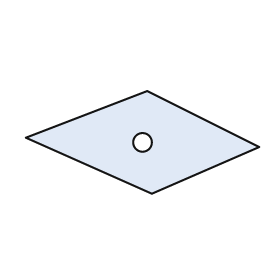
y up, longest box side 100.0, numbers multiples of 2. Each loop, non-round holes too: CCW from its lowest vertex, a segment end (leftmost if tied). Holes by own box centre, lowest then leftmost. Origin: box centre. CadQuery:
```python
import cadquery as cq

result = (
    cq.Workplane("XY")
    .moveTo(4.0, -22.0)
    .lineTo(50.0, -2.0)
    .lineTo(2.0, 22.0)
    .lineTo(-50.0, 2.0)
    .close()
    .moveTo(0.0, 0.0)
    .circle(4.0)
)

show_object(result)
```